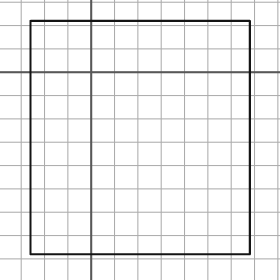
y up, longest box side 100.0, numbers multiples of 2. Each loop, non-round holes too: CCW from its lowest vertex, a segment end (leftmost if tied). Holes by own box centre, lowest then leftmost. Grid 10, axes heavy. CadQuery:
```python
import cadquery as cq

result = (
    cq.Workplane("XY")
    .moveTo(-26.0, -78.0)
    .lineTo(68.0, -78.0)
    .lineTo(68.0, 22.0)
    .lineTo(-26.0, 22.0)
    .close()
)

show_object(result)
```